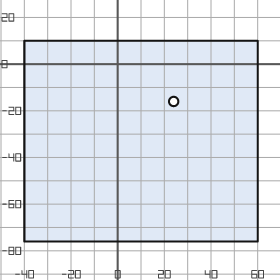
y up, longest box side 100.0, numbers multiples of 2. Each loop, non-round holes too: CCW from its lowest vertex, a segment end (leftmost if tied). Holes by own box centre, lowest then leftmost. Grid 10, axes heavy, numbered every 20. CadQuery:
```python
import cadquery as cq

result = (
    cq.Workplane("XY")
    .moveTo(-40.0, -76.0)
    .lineTo(60.0, -76.0)
    .lineTo(60.0, 10.0)
    .lineTo(-40.0, 10.0)
    .close()
    .moveTo(24.0, -16.0)
    .circle(2.0)
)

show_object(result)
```